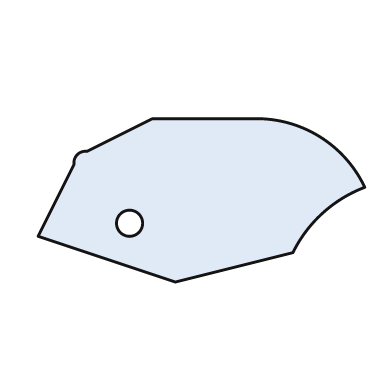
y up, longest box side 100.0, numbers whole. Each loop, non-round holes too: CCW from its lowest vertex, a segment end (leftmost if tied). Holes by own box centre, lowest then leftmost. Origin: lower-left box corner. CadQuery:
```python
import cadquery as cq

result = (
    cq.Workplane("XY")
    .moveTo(42.0, 0.0)
    .lineTo(78.0, 9.0)
    .threePointArc((87.0, 21.0), (100.0, 29.0))
    .threePointArc((87.0, 44.0), (68.0, 50.0))
    .lineTo(35.0, 50.0)
    .lineTo(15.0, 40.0)
    .threePointArc((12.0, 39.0), (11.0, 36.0))
    .lineTo(0.0, 14.0)
    .close()
    .moveTo(28.0, 18.0)
    .circle(4.0)
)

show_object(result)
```